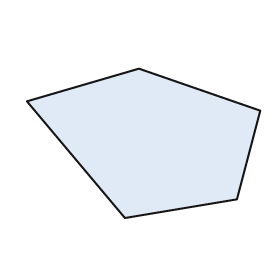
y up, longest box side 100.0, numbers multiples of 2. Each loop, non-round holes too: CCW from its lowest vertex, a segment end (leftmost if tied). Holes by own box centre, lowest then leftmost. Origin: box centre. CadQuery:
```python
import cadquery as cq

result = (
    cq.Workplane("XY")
    .moveTo(-8.0, -32.0)
    .lineTo(40.0, -24.0)
    .lineTo(50.0, 14.0)
    .lineTo(-2.0, 32.0)
    .lineTo(-50.0, 18.0)
    .close()
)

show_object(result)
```